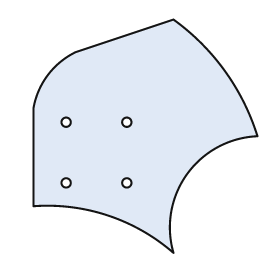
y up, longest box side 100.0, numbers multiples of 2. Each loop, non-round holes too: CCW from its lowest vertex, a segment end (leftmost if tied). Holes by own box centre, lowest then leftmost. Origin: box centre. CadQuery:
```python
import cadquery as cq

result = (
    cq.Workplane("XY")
    .moveTo(12.0, -50.0)
    .threePointArc((18.0, -16.0), (48.0, 0.0))
    .threePointArc((34.0, 28.0), (12.0, 50.0))
    .lineTo(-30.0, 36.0)
    .threePointArc((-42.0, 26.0), (-48.0, 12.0))
    .lineTo(-48.0, -30.0)
    .threePointArc((-16.0, -34.0), (12.0, -50.0))
    .close()
    .moveTo(-34.0, -20.0)
    .circle(2.0)
    .moveTo(-8.0, -20.0)
    .circle(2.0)
    .moveTo(-34.0, 6.0)
    .circle(2.0)
    .moveTo(-8.0, 6.0)
    .circle(2.0)
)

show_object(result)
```